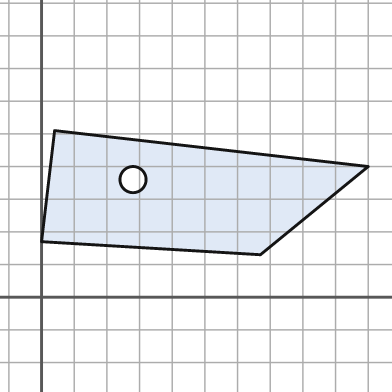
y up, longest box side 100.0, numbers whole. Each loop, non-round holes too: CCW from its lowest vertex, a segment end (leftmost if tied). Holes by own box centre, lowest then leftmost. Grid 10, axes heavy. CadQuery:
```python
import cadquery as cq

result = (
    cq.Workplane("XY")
    .moveTo(67.0, 13.0)
    .lineTo(100.0, 40.0)
    .lineTo(4.0, 51.0)
    .lineTo(0.0, 17.0)
    .close()
    .moveTo(28.0, 36.0)
    .circle(4.0)
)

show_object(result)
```